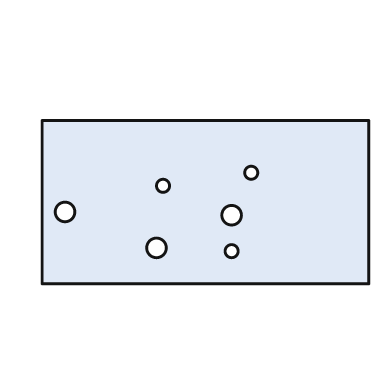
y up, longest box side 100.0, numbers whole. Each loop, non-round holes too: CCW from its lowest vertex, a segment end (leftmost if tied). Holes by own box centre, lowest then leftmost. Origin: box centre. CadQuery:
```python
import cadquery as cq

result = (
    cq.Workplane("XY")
    .moveTo(-50.0, -25.0)
    .lineTo(50.0, -25.0)
    .lineTo(50.0, 25.0)
    .lineTo(-50.0, 25.0)
    .close()
    .moveTo(8.0, -15.0)
    .circle(2.0)
    .moveTo(-15.0, -14.0)
    .circle(3.0)
    .moveTo(8.0, -4.0)
    .circle(3.0)
    .moveTo(-43.0, -3.0)
    .circle(3.0)
    .moveTo(-13.0, 5.0)
    .circle(2.0)
    .moveTo(14.0, 9.0)
    .circle(2.0)
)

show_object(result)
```